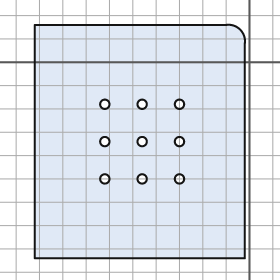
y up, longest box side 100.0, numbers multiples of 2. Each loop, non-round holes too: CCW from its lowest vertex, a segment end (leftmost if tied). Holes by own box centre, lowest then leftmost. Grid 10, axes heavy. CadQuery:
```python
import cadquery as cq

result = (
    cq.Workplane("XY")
    .moveTo(-92.0, -84.0)
    .lineTo(-2.0, -84.0)
    .lineTo(-2.0, 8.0)
    .threePointArc((-4.0, 14.0), (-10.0, 16.0))
    .lineTo(-92.0, 16.0)
    .close()
    .moveTo(-62.0, -50.0)
    .circle(2.0)
    .moveTo(-46.0, -50.0)
    .circle(2.0)
    .moveTo(-30.0, -50.0)
    .circle(2.0)
    .moveTo(-62.0, -34.0)
    .circle(2.0)
    .moveTo(-46.0, -34.0)
    .circle(2.0)
    .moveTo(-30.0, -34.0)
    .circle(2.0)
    .moveTo(-62.0, -18.0)
    .circle(2.0)
    .moveTo(-46.0, -18.0)
    .circle(2.0)
    .moveTo(-30.0, -18.0)
    .circle(2.0)
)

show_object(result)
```